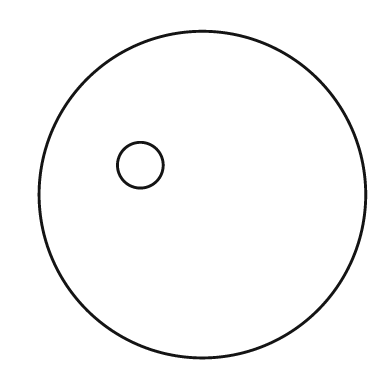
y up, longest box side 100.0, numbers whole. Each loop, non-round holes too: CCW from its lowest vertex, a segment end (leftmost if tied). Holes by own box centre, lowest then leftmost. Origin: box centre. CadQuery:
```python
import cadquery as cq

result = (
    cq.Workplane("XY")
    .moveTo(0.0, 0.0)
    .circle(50.0)
    .moveTo(-19.0, 9.0)
    .circle(7.0)
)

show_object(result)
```